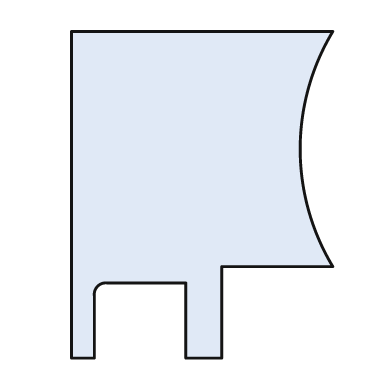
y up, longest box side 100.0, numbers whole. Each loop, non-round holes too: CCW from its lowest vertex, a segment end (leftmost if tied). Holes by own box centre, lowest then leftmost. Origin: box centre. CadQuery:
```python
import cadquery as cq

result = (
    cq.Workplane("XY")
    .moveTo(-40.0, -50.0)
    .lineTo(-33.0, -50.0)
    .lineTo(-33.0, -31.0)
    .threePointArc((-32.0, -28.0), (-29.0, -27.0))
    .lineTo(-5.0, -27.0)
    .lineTo(-5.0, -50.0)
    .lineTo(6.0, -50.0)
    .lineTo(6.0, -22.0)
    .lineTo(40.0, -22.0)
    .threePointArc((30.0, 14.0), (40.0, 50.0))
    .lineTo(-40.0, 50.0)
    .close()
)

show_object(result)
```